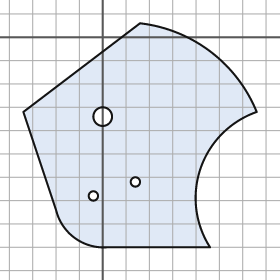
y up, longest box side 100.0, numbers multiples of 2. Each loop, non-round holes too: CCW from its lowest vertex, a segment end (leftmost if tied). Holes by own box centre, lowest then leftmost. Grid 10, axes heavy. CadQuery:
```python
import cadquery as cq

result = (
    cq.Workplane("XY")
    .moveTo(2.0, -90.0)
    .lineTo(46.0, -90.0)
    .threePointArc((42.0, -56.0), (66.0, -32.0))
    .threePointArc((46.0, -6.0), (16.0, 6.0))
    .lineTo(-34.0, -32.0)
    .lineTo(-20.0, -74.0)
    .threePointArc((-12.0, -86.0), (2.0, -90.0))
    .close()
    .moveTo(-4.0, -68.0)
    .circle(2.0)
    .moveTo(14.0, -62.0)
    .circle(2.0)
    .moveTo(0.0, -34.0)
    .circle(4.0)
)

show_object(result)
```